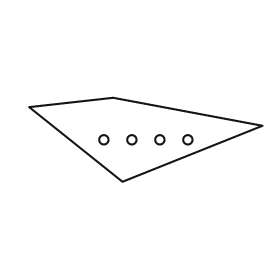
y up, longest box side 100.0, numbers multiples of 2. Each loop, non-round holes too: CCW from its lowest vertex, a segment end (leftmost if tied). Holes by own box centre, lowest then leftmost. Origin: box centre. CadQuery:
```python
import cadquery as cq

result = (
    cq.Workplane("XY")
    .moveTo(-10.0, -18.0)
    .lineTo(50.0, 6.0)
    .lineTo(-14.0, 18.0)
    .lineTo(-50.0, 14.0)
    .close()
    .moveTo(-18.0, 0.0)
    .circle(2.0)
    .moveTo(-6.0, 0.0)
    .circle(2.0)
    .moveTo(6.0, 0.0)
    .circle(2.0)
    .moveTo(18.0, 0.0)
    .circle(2.0)
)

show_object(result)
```